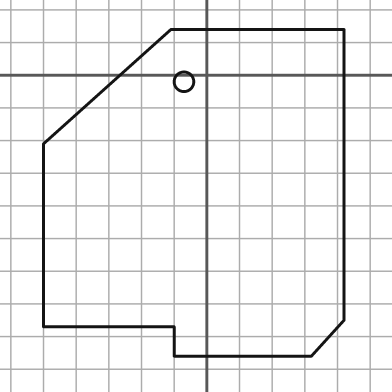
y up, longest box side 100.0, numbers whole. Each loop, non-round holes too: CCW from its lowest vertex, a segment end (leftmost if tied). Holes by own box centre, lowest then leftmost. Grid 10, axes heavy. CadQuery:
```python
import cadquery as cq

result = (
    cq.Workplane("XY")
    .moveTo(-10.0, -86.0)
    .lineTo(32.0, -86.0)
    .lineTo(42.0, -75.0)
    .lineTo(42.0, 14.0)
    .lineTo(-11.0, 14.0)
    .lineTo(-50.0, -21.0)
    .lineTo(-50.0, -77.0)
    .lineTo(-10.0, -77.0)
    .close()
    .moveTo(-7.0, -2.0)
    .circle(3.0)
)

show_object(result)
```